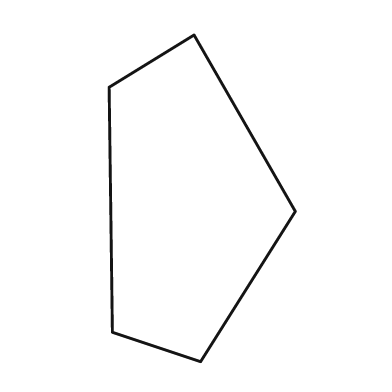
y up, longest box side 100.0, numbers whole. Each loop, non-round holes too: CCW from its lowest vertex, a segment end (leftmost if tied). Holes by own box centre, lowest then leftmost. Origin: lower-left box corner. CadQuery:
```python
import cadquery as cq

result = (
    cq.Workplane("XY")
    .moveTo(28.0, 0.0)
    .lineTo(57.0, 46.0)
    .lineTo(26.0, 100.0)
    .lineTo(0.0, 84.0)
    .lineTo(1.0, 9.0)
    .close()
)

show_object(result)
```